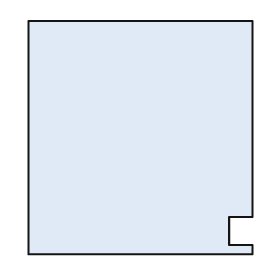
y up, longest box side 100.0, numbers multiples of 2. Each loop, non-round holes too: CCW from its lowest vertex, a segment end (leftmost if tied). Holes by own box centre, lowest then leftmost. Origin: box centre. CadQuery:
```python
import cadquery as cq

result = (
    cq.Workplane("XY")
    .moveTo(-48.0, -50.0)
    .lineTo(48.0, -50.0)
    .lineTo(48.0, -46.0)
    .lineTo(38.0, -46.0)
    .lineTo(38.0, -34.0)
    .lineTo(48.0, -34.0)
    .lineTo(48.0, 50.0)
    .lineTo(-48.0, 50.0)
    .close()
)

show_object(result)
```